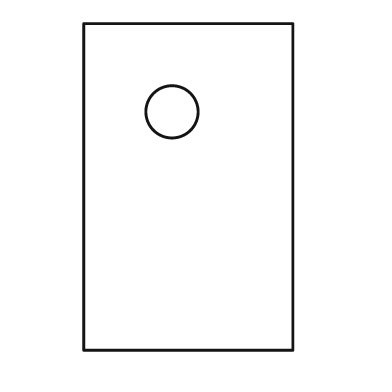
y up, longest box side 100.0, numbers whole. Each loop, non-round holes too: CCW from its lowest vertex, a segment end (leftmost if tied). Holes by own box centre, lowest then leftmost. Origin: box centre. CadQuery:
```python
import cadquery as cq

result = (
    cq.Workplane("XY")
    .moveTo(-32.0, -50.0)
    .lineTo(32.0, -50.0)
    .lineTo(32.0, 50.0)
    .lineTo(-32.0, 50.0)
    .close()
    .moveTo(-5.0, 23.0)
    .circle(8.0)
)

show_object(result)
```